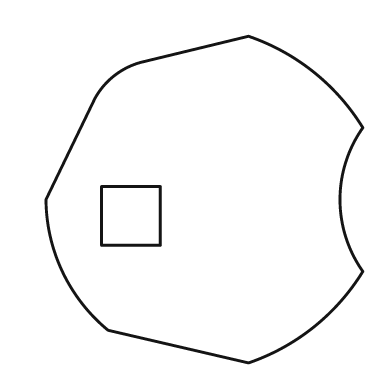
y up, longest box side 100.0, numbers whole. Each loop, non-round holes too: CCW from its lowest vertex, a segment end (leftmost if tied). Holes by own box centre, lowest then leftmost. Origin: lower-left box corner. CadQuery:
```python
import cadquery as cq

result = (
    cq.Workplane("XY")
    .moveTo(62.0, 0.0)
    .threePointArc((82.0, 11.0), (97.0, 28.0))
    .threePointArc((90.0, 50.0), (97.0, 72.0))
    .threePointArc((82.0, 89.0), (62.0, 100.0))
    .lineTo(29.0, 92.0)
    .threePointArc((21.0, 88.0), (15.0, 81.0))
    .lineTo(0.0, 50.0)
    .threePointArc((5.0, 28.0), (19.0, 10.0))
    .close()
    .moveTo(17.0, 36.0)
    .lineTo(35.0, 36.0)
    .lineTo(35.0, 54.0)
    .lineTo(17.0, 54.0)
    .close()
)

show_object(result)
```